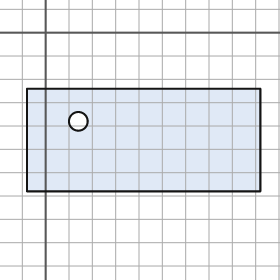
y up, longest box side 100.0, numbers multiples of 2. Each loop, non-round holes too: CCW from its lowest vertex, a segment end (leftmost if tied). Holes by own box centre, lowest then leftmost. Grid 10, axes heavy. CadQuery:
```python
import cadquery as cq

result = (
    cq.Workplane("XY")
    .moveTo(-8.0, -68.0)
    .lineTo(92.0, -68.0)
    .lineTo(92.0, -24.0)
    .lineTo(-8.0, -24.0)
    .close()
    .moveTo(14.0, -38.0)
    .circle(4.0)
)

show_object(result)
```